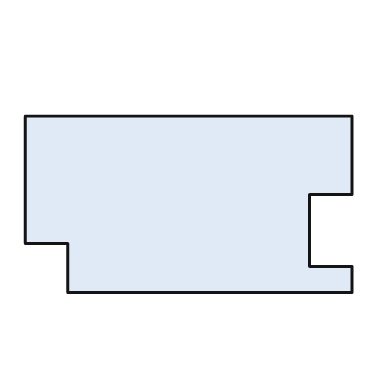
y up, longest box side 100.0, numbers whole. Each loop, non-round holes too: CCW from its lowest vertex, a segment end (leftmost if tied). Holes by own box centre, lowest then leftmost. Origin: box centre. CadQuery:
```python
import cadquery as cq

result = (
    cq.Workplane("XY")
    .moveTo(-37.0, -27.0)
    .lineTo(50.0, -27.0)
    .lineTo(50.0, -19.0)
    .lineTo(37.0, -19.0)
    .lineTo(37.0, 3.0)
    .lineTo(50.0, 3.0)
    .lineTo(50.0, 27.0)
    .lineTo(-50.0, 27.0)
    .lineTo(-50.0, -12.0)
    .lineTo(-37.0, -12.0)
    .close()
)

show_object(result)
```